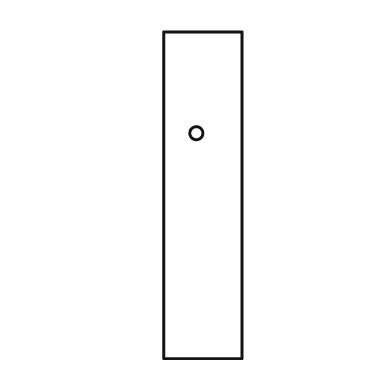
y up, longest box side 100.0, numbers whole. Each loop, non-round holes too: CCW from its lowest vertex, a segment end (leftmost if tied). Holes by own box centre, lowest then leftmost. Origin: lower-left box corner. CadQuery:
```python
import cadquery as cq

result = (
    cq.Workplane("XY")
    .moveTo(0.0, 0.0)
    .lineTo(24.0, 0.0)
    .lineTo(24.0, 100.0)
    .lineTo(0.0, 100.0)
    .close()
    .moveTo(10.0, 69.0)
    .circle(2.0)
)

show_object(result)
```